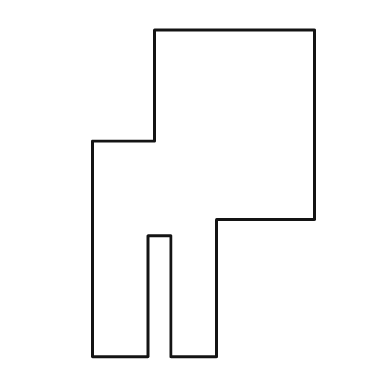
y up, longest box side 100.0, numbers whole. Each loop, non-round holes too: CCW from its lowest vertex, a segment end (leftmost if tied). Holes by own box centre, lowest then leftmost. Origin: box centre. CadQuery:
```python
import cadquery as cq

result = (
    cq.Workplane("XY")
    .moveTo(-34.0, -50.0)
    .lineTo(-17.0, -50.0)
    .lineTo(-17.0, -13.0)
    .lineTo(-10.0, -13.0)
    .lineTo(-10.0, -50.0)
    .lineTo(4.0, -50.0)
    .lineTo(4.0, -8.0)
    .lineTo(34.0, -8.0)
    .lineTo(34.0, 50.0)
    .lineTo(-15.0, 50.0)
    .lineTo(-15.0, 16.0)
    .lineTo(-34.0, 16.0)
    .close()
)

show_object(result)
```